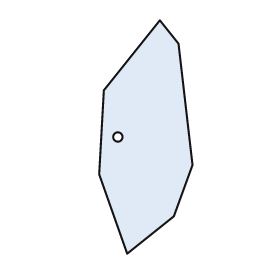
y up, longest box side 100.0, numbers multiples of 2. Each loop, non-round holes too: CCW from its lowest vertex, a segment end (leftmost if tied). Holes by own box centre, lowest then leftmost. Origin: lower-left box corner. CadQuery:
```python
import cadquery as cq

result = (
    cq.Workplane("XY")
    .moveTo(12.0, 0.0)
    .lineTo(32.0, 16.0)
    .lineTo(40.0, 38.0)
    .lineTo(34.0, 90.0)
    .lineTo(26.0, 100.0)
    .lineTo(2.0, 70.0)
    .lineTo(0.0, 34.0)
    .close()
    .moveTo(8.0, 50.0)
    .circle(2.0)
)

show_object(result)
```